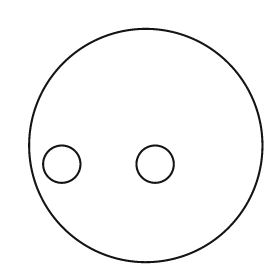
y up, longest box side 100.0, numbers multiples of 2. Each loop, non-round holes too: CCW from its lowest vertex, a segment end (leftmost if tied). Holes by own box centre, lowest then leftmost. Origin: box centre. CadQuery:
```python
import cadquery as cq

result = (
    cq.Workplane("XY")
    .moveTo(0.0, 0.0)
    .circle(50.0)
    .moveTo(-36.0, -8.0)
    .circle(8.0)
    .moveTo(4.0, -8.0)
    .circle(8.0)
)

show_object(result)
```